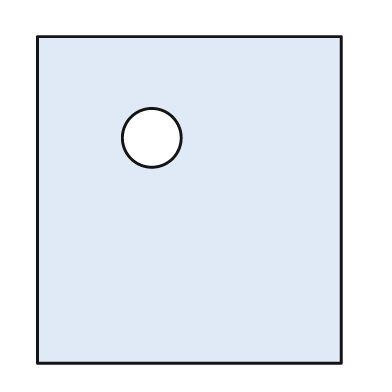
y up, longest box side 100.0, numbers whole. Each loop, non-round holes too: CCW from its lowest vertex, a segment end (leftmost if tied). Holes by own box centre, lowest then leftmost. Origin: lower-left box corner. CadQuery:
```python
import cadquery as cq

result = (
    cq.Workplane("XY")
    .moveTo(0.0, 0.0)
    .lineTo(93.0, 0.0)
    .lineTo(93.0, 100.0)
    .lineTo(0.0, 100.0)
    .close()
    .moveTo(35.0, 69.0)
    .circle(9.0)
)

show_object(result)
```